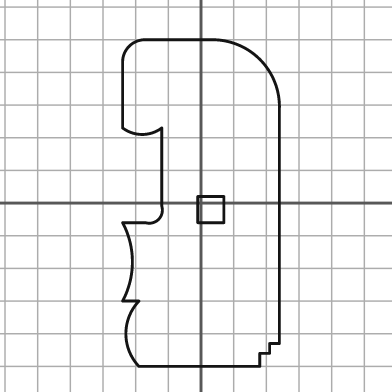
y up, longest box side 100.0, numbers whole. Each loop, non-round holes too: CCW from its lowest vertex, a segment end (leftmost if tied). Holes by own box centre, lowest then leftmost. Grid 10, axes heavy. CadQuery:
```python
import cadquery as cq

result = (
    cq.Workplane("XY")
    .moveTo(-19.0, -50.0)
    .lineTo(18.0, -50.0)
    .lineTo(18.0, -46.0)
    .lineTo(21.0, -46.0)
    .lineTo(21.0, -43.0)
    .lineTo(24.0, -43.0)
    .lineTo(24.0, 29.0)
    .threePointArc((18.0, 44.0), (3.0, 50.0))
    .lineTo(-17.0, 50.0)
    .threePointArc((-22.0, 48.0), (-24.0, 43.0))
    .lineTo(-24.0, 23.0)
    .threePointArc((-18.0, 21.0), (-12.0, 23.0))
    .lineTo(-12.0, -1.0)
    .threePointArc((-13.0, -5.0), (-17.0, -6.0))
    .lineTo(-24.0, -6.0)
    .threePointArc((-21.0, -18.0), (-24.0, -30.0))
    .lineTo(-19.0, -30.0)
    .threePointArc((-23.0, -40.0), (-19.0, -50.0))
    .close()
    .moveTo(-1.0, -6.0)
    .lineTo(7.0, -6.0)
    .lineTo(7.0, 2.0)
    .lineTo(-1.0, 2.0)
    .close()
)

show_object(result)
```